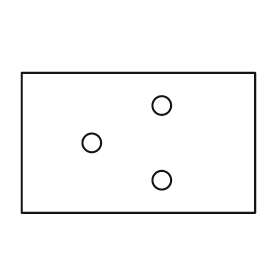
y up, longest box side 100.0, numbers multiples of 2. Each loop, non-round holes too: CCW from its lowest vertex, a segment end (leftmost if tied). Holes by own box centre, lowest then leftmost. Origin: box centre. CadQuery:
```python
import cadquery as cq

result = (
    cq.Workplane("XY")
    .moveTo(-50.0, -30.0)
    .lineTo(50.0, -30.0)
    .lineTo(50.0, 30.0)
    .lineTo(-50.0, 30.0)
    .close()
    .moveTo(10.0, -16.0)
    .circle(4.0)
    .moveTo(-20.0, 0.0)
    .circle(4.0)
    .moveTo(10.0, 16.0)
    .circle(4.0)
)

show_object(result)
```